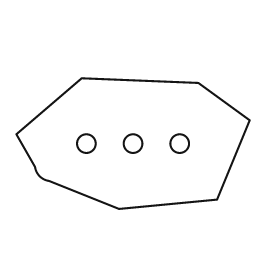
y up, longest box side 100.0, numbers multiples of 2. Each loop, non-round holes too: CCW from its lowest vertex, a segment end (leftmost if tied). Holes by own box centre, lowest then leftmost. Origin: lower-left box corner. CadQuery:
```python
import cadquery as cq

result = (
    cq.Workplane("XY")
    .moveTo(44.0, 0.0)
    .lineTo(86.0, 4.0)
    .lineTo(100.0, 38.0)
    .lineTo(78.0, 54.0)
    .lineTo(28.0, 56.0)
    .lineTo(0.0, 32.0)
    .lineTo(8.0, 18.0)
    .threePointArc((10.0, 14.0), (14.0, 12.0))
    .close()
    .moveTo(30.0, 28.0)
    .circle(4.0)
    .moveTo(50.0, 28.0)
    .circle(4.0)
    .moveTo(70.0, 28.0)
    .circle(4.0)
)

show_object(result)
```